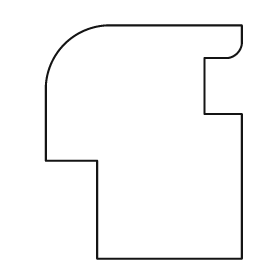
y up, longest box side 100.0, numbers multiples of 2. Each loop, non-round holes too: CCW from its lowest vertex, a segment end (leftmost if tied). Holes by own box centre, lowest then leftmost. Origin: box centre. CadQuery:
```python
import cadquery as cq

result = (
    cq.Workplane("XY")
    .moveTo(-20.0, -50.0)
    .lineTo(42.0, -50.0)
    .lineTo(42.0, 12.0)
    .lineTo(26.0, 12.0)
    .lineTo(26.0, 36.0)
    .lineTo(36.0, 36.0)
    .threePointArc((40.0, 38.0), (42.0, 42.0))
    .lineTo(42.0, 50.0)
    .lineTo(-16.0, 50.0)
    .threePointArc((-34.0, 42.0), (-42.0, 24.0))
    .lineTo(-42.0, -8.0)
    .lineTo(-20.0, -8.0)
    .close()
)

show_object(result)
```